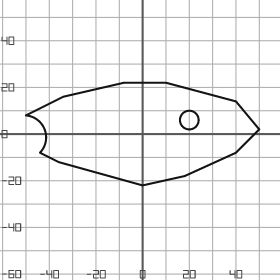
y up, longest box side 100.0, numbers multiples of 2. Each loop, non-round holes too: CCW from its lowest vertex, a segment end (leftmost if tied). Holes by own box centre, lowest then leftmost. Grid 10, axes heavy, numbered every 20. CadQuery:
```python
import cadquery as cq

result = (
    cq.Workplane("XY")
    .moveTo(0.0, -22.0)
    .lineTo(18.0, -18.0)
    .lineTo(40.0, -8.0)
    .lineTo(50.0, 2.0)
    .lineTo(40.0, 14.0)
    .lineTo(10.0, 22.0)
    .lineTo(-8.0, 22.0)
    .lineTo(-34.0, 16.0)
    .lineTo(-50.0, 8.0)
    .threePointArc((-42.0, 2.0), (-44.0, -8.0))
    .lineTo(-36.0, -12.0)
    .close()
    .moveTo(20.0, 6.0)
    .circle(4.0)
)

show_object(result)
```